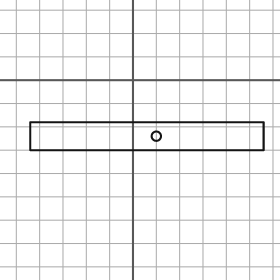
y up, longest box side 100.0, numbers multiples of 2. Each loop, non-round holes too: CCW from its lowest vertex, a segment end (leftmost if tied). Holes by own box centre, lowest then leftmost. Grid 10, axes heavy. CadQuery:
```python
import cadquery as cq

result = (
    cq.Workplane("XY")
    .moveTo(-44.0, -30.0)
    .lineTo(56.0, -30.0)
    .lineTo(56.0, -18.0)
    .lineTo(-44.0, -18.0)
    .close()
    .moveTo(10.0, -24.0)
    .circle(2.0)
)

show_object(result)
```